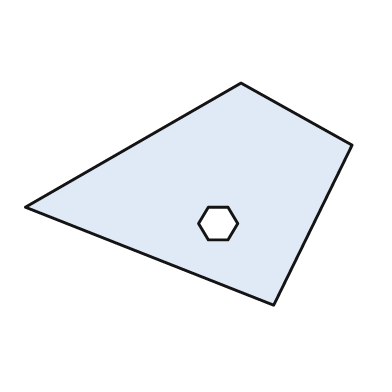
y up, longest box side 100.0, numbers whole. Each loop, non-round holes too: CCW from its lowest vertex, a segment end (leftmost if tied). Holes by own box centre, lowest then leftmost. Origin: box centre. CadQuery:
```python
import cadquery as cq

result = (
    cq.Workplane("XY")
    .moveTo(26.0, -34.0)
    .lineTo(50.0, 15.0)
    .lineTo(16.0, 34.0)
    .lineTo(-50.0, -4.0)
    .close()
    .moveTo(6.0, -14.0)
    .lineTo(12.0, -14.0)
    .lineTo(15.0, -9.0)
    .lineTo(12.0, -4.0)
    .lineTo(6.0, -4.0)
    .lineTo(3.0, -9.0)
    .close()
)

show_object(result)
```